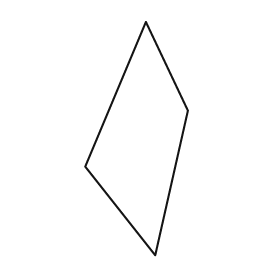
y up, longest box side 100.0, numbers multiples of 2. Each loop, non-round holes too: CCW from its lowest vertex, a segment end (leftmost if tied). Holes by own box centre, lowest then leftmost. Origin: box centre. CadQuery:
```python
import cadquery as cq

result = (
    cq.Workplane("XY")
    .moveTo(8.0, -50.0)
    .lineTo(22.0, 12.0)
    .lineTo(4.0, 50.0)
    .lineTo(-22.0, -12.0)
    .close()
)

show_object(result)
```